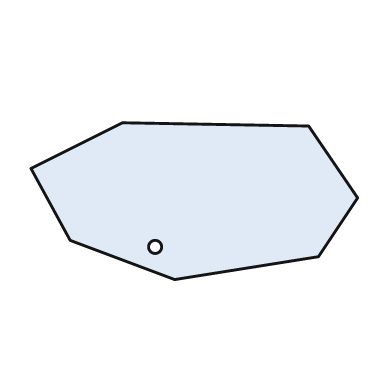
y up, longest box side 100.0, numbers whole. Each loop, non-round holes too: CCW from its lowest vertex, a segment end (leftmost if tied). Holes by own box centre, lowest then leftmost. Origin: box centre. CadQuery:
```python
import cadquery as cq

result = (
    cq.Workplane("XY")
    .moveTo(-6.0, -24.0)
    .lineTo(38.0, -17.0)
    .lineTo(50.0, 1.0)
    .lineTo(35.0, 23.0)
    .lineTo(-22.0, 24.0)
    .lineTo(-50.0, 10.0)
    .lineTo(-38.0, -12.0)
    .close()
    .moveTo(-12.0, -14.0)
    .circle(2.0)
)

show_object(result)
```